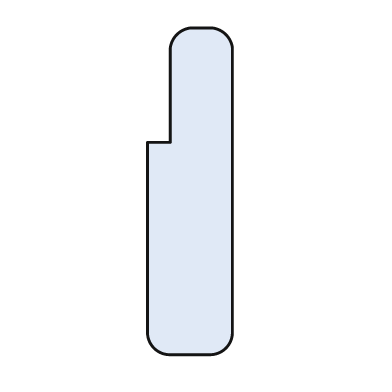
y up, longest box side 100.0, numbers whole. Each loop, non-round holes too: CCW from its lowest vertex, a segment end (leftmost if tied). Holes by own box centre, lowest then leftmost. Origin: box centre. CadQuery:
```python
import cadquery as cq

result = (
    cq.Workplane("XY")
    .moveTo(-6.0, -50.0)
    .lineTo(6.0, -50.0)
    .threePointArc((11.0, -48.0), (13.0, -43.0))
    .lineTo(13.0, 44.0)
    .threePointArc((11.0, 48.0), (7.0, 50.0))
    .lineTo(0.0, 50.0)
    .threePointArc((-4.0, 48.0), (-6.0, 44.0))
    .lineTo(-6.0, 15.0)
    .lineTo(-13.0, 15.0)
    .lineTo(-13.0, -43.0)
    .threePointArc((-11.0, -48.0), (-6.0, -50.0))
    .close()
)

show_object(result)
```